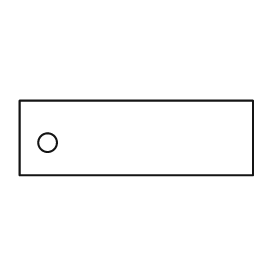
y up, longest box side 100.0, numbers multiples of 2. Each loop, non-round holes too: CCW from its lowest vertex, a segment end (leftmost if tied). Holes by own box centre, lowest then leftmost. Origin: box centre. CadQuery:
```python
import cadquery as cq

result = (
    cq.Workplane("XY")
    .moveTo(-50.0, -16.0)
    .lineTo(50.0, -16.0)
    .lineTo(50.0, 16.0)
    .lineTo(-50.0, 16.0)
    .close()
    .moveTo(-38.0, -2.0)
    .circle(4.0)
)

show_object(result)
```